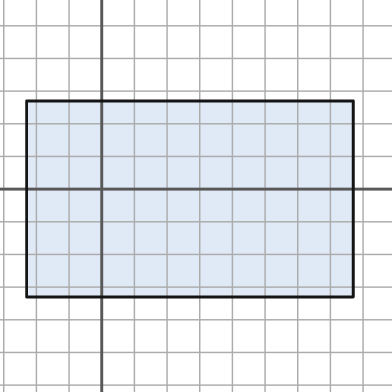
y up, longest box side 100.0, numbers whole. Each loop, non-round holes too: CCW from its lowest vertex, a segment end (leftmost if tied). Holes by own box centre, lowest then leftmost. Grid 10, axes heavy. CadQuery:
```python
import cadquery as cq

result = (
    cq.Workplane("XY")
    .moveTo(-23.0, -33.0)
    .lineTo(77.0, -33.0)
    .lineTo(77.0, 27.0)
    .lineTo(-23.0, 27.0)
    .close()
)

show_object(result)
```